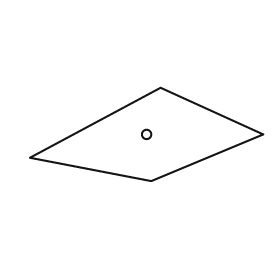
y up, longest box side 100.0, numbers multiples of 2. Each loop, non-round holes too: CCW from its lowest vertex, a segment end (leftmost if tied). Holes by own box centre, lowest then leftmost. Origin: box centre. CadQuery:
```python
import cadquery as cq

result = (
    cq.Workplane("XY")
    .moveTo(2.0, -20.0)
    .lineTo(50.0, 0.0)
    .lineTo(6.0, 20.0)
    .lineTo(-50.0, -10.0)
    .close()
    .moveTo(0.0, 0.0)
    .circle(2.0)
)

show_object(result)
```